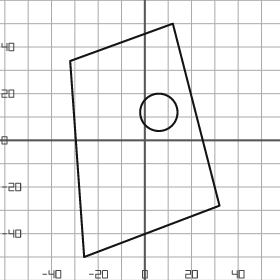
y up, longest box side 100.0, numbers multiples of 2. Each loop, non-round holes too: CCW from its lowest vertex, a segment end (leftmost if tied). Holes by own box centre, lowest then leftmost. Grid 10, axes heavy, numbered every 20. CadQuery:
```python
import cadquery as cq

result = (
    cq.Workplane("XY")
    .moveTo(-26.0, -50.0)
    .lineTo(32.0, -28.0)
    .lineTo(12.0, 50.0)
    .lineTo(-32.0, 34.0)
    .close()
    .moveTo(6.0, 12.0)
    .circle(8.0)
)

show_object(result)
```